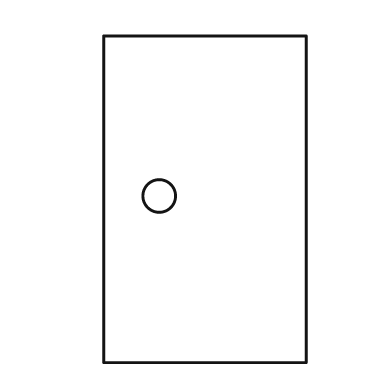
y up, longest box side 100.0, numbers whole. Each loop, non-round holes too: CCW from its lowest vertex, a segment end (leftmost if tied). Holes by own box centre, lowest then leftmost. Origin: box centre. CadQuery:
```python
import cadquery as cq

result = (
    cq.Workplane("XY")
    .moveTo(-31.0, -50.0)
    .lineTo(31.0, -50.0)
    .lineTo(31.0, 50.0)
    .lineTo(-31.0, 50.0)
    .close()
    .moveTo(-14.0, 1.0)
    .circle(5.0)
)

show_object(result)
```